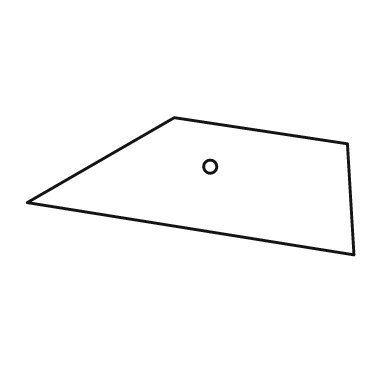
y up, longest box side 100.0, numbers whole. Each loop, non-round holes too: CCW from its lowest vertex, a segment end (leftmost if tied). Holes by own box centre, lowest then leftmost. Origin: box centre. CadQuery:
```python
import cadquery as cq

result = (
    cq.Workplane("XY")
    .moveTo(50.0, -21.0)
    .lineTo(48.0, 13.0)
    .lineTo(-5.0, 21.0)
    .lineTo(-50.0, -5.0)
    .close()
    .moveTo(6.0, 6.0)
    .circle(2.0)
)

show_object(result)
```